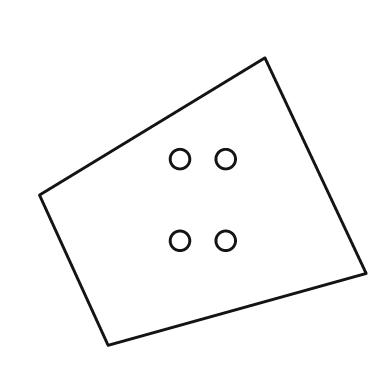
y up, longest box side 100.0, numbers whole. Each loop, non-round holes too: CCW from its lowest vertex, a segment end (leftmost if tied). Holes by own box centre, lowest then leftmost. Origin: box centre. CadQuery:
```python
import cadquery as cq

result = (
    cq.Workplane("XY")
    .moveTo(-29.0, -44.0)
    .lineTo(50.0, -22.0)
    .lineTo(19.0, 44.0)
    .lineTo(-50.0, 2.0)
    .close()
    .moveTo(-7.0, -12.0)
    .circle(3.0)
    .moveTo(7.0, -12.0)
    .circle(3.0)
    .moveTo(-7.0, 13.0)
    .circle(3.0)
    .moveTo(7.0, 13.0)
    .circle(3.0)
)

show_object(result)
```